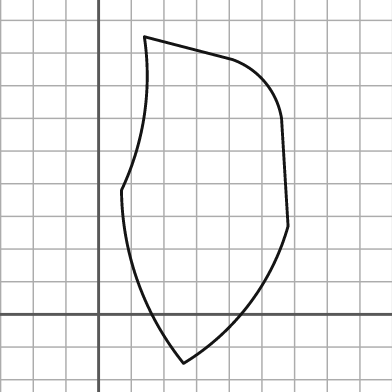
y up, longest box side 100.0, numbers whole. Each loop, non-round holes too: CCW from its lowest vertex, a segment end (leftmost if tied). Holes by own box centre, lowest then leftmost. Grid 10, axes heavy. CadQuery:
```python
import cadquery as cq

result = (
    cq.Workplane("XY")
    .moveTo(26.0, -15.0)
    .threePointArc((46.0, 3.0), (58.0, 27.0))
    .lineTo(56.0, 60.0)
    .threePointArc((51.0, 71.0), (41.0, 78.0))
    .lineTo(14.0, 85.0)
    .threePointArc((14.0, 61.0), (7.0, 38.0))
    .threePointArc((12.0, 10.0), (26.0, -15.0))
    .close()
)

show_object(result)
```